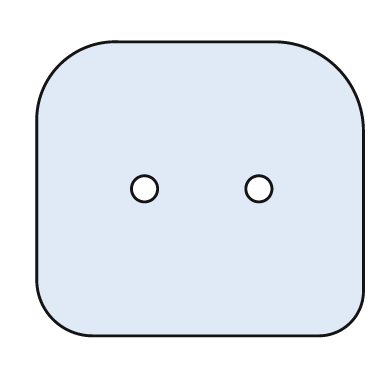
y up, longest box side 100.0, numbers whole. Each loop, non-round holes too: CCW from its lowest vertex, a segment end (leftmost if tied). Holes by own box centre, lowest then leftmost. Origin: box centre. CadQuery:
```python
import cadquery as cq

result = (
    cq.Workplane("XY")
    .moveTo(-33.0, -45.0)
    .lineTo(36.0, -45.0)
    .threePointArc((46.0, -41.0), (50.0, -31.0))
    .lineTo(50.0, 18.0)
    .threePointArc((42.0, 37.0), (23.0, 45.0))
    .lineTo(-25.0, 45.0)
    .threePointArc((-43.0, 38.0), (-50.0, 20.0))
    .lineTo(-50.0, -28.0)
    .threePointArc((-45.0, -40.0), (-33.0, -45.0))
    .close()
    .moveTo(-17.0, 0.0)
    .circle(4.0)
    .moveTo(18.0, 0.0)
    .circle(4.0)
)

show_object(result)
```